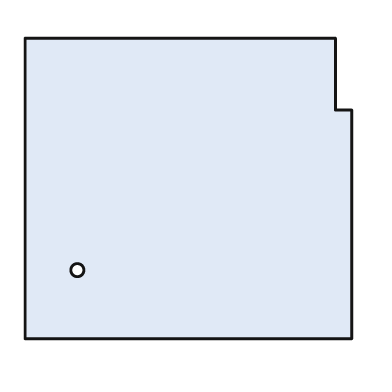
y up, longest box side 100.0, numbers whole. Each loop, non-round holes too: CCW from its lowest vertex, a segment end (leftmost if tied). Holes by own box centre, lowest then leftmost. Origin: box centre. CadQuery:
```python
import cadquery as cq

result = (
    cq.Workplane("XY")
    .moveTo(-50.0, -46.0)
    .lineTo(50.0, -46.0)
    .lineTo(50.0, 24.0)
    .lineTo(45.0, 24.0)
    .lineTo(45.0, 46.0)
    .lineTo(-50.0, 46.0)
    .close()
    .moveTo(-34.0, -25.0)
    .circle(2.0)
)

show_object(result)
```